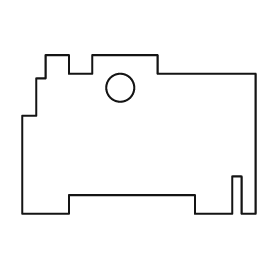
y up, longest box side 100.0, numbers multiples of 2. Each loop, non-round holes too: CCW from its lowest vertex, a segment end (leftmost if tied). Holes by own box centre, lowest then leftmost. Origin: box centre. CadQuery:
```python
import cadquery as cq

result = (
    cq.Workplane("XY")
    .moveTo(-50.0, -34.0)
    .lineTo(-30.0, -34.0)
    .lineTo(-30.0, -26.0)
    .lineTo(24.0, -26.0)
    .lineTo(24.0, -34.0)
    .lineTo(40.0, -34.0)
    .lineTo(40.0, -18.0)
    .lineTo(44.0, -18.0)
    .lineTo(44.0, -34.0)
    .lineTo(50.0, -34.0)
    .lineTo(50.0, 26.0)
    .lineTo(8.0, 26.0)
    .lineTo(8.0, 34.0)
    .lineTo(-20.0, 34.0)
    .lineTo(-20.0, 26.0)
    .lineTo(-30.0, 26.0)
    .lineTo(-30.0, 34.0)
    .lineTo(-40.0, 34.0)
    .lineTo(-40.0, 24.0)
    .lineTo(-44.0, 24.0)
    .lineTo(-44.0, 8.0)
    .lineTo(-50.0, 8.0)
    .close()
    .moveTo(-8.0, 20.0)
    .circle(6.0)
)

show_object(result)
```